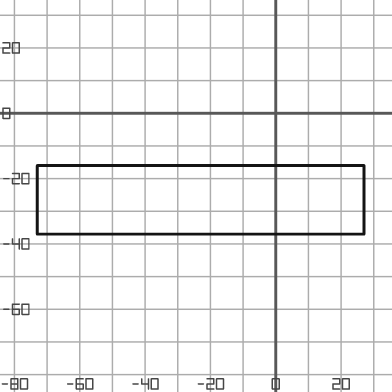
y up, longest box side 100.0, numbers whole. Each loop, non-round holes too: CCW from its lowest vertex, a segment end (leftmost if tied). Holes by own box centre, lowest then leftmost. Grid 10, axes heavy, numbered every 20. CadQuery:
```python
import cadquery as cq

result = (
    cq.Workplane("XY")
    .moveTo(-73.0, -37.0)
    .lineTo(27.0, -37.0)
    .lineTo(27.0, -16.0)
    .lineTo(-73.0, -16.0)
    .close()
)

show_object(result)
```